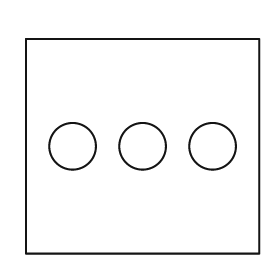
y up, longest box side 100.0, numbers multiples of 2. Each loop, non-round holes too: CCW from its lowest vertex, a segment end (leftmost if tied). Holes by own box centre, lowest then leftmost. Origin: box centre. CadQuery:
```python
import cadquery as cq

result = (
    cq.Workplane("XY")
    .moveTo(-50.0, -46.0)
    .lineTo(50.0, -46.0)
    .lineTo(50.0, 46.0)
    .lineTo(-50.0, 46.0)
    .close()
    .moveTo(-30.0, 0.0)
    .circle(10.0)
    .moveTo(0.0, 0.0)
    .circle(10.0)
    .moveTo(30.0, 0.0)
    .circle(10.0)
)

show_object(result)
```